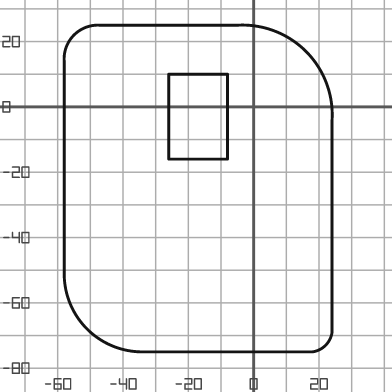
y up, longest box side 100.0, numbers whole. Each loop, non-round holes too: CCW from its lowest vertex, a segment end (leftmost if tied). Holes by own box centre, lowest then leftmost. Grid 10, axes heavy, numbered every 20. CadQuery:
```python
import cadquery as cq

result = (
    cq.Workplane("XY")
    .moveTo(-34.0, -75.0)
    .lineTo(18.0, -75.0)
    .threePointArc((22.0, -73.0), (24.0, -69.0))
    .lineTo(24.0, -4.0)
    .threePointArc((16.0, 17.0), (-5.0, 25.0))
    .lineTo(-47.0, 25.0)
    .threePointArc((-55.0, 22.0), (-58.0, 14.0))
    .lineTo(-58.0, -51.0)
    .threePointArc((-51.0, -68.0), (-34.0, -75.0))
    .close()
    .moveTo(-26.0, -16.0)
    .lineTo(-8.0, -16.0)
    .lineTo(-8.0, 10.0)
    .lineTo(-26.0, 10.0)
    .close()
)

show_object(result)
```